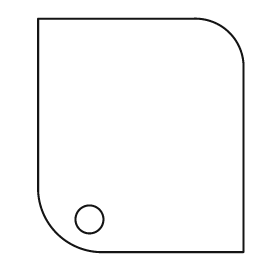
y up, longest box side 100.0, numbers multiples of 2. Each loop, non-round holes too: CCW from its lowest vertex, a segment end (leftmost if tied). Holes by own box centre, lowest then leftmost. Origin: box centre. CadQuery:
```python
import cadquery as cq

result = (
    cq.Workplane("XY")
    .moveTo(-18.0, -50.0)
    .lineTo(44.0, -50.0)
    .lineTo(44.0, 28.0)
    .threePointArc((38.0, 44.0), (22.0, 50.0))
    .lineTo(-44.0, 50.0)
    .lineTo(-44.0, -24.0)
    .threePointArc((-36.0, -42.0), (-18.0, -50.0))
    .close()
    .moveTo(-22.0, -36.0)
    .circle(6.0)
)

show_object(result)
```